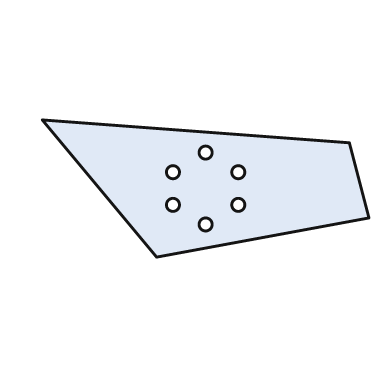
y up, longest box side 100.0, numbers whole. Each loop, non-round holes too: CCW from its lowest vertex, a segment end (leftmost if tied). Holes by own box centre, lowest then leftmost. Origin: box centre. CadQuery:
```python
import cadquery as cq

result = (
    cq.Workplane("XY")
    .moveTo(-15.0, -21.0)
    .lineTo(50.0, -9.0)
    .lineTo(44.0, 14.0)
    .lineTo(-50.0, 21.0)
    .close()
    .moveTo(0.0, -11.0)
    .circle(2.0)
    .moveTo(-10.0, -5.0)
    .circle(2.0)
    .moveTo(10.0, -5.0)
    .circle(2.0)
    .moveTo(-10.0, 5.0)
    .circle(2.0)
    .moveTo(10.0, 5.0)
    .circle(2.0)
    .moveTo(0.0, 11.0)
    .circle(2.0)
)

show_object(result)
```